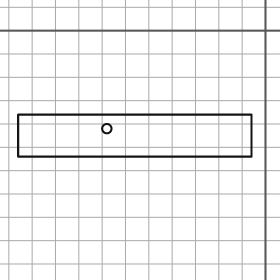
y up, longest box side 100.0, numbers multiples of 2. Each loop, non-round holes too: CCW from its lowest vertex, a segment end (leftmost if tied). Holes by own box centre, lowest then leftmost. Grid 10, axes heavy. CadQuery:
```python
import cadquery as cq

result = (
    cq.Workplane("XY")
    .moveTo(-106.0, -54.0)
    .lineTo(-6.0, -54.0)
    .lineTo(-6.0, -36.0)
    .lineTo(-106.0, -36.0)
    .close()
    .moveTo(-68.0, -42.0)
    .circle(2.0)
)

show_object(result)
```